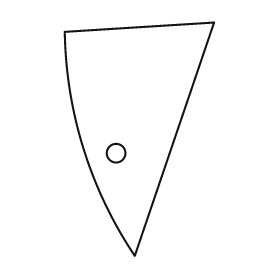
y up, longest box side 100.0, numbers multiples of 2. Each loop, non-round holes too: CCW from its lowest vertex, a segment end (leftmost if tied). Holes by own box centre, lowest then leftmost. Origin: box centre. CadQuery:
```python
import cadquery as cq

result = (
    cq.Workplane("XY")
    .moveTo(-2.0, -50.0)
    .lineTo(32.0, 50.0)
    .lineTo(-32.0, 46.0)
    .threePointArc((-24.0, -4.0), (-2.0, -50.0))
    .close()
    .moveTo(-10.0, -6.0)
    .circle(4.0)
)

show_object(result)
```